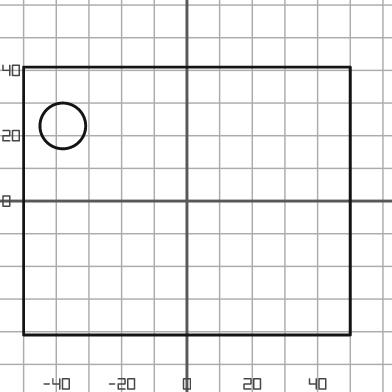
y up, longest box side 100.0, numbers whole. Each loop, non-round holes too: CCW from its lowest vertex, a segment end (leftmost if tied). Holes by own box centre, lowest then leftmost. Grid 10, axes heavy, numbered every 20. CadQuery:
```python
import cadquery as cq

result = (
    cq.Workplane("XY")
    .moveTo(-50.0, -41.0)
    .lineTo(50.0, -41.0)
    .lineTo(50.0, 41.0)
    .lineTo(-50.0, 41.0)
    .close()
    .moveTo(-38.0, 23.0)
    .circle(7.0)
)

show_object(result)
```